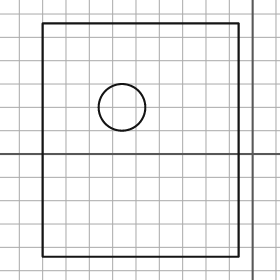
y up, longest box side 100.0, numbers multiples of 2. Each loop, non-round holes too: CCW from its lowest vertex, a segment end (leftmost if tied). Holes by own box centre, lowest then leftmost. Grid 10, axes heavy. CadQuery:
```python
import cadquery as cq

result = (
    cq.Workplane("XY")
    .moveTo(-90.0, -44.0)
    .lineTo(-6.0, -44.0)
    .lineTo(-6.0, 56.0)
    .lineTo(-90.0, 56.0)
    .close()
    .moveTo(-56.0, 20.0)
    .circle(10.0)
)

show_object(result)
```